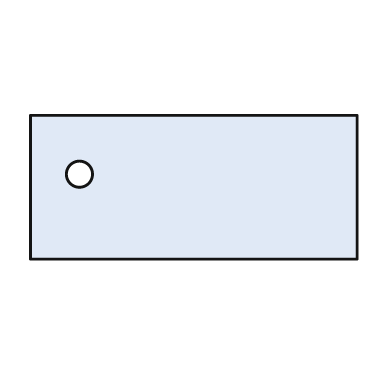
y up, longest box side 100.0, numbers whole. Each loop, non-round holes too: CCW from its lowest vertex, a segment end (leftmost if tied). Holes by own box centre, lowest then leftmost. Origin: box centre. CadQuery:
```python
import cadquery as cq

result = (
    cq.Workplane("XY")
    .moveTo(-50.0, -22.0)
    .lineTo(50.0, -22.0)
    .lineTo(50.0, 22.0)
    .lineTo(-50.0, 22.0)
    .close()
    .moveTo(-35.0, 4.0)
    .circle(4.0)
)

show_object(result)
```